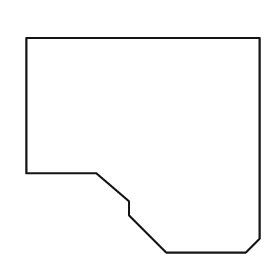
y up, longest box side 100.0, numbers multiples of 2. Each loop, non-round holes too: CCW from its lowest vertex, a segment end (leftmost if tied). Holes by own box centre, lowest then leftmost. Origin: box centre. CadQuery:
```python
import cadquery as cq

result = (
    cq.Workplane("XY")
    .moveTo(10.0, -46.0)
    .lineTo(44.0, -46.0)
    .lineTo(50.0, -40.0)
    .lineTo(50.0, 46.0)
    .lineTo(-50.0, 46.0)
    .lineTo(-50.0, -12.0)
    .lineTo(-20.0, -12.0)
    .lineTo(-6.0, -24.0)
    .lineTo(-6.0, -30.0)
    .close()
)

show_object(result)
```